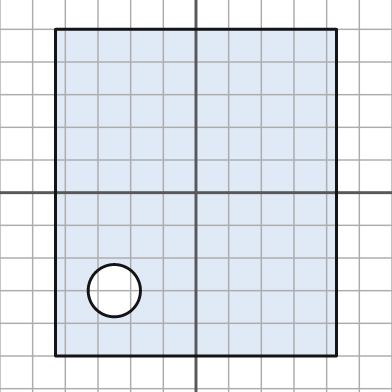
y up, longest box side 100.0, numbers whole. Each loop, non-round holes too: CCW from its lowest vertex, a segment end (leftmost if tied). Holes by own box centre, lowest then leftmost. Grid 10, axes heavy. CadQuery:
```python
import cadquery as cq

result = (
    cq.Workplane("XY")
    .moveTo(-43.0, -50.0)
    .lineTo(43.0, -50.0)
    .lineTo(43.0, 50.0)
    .lineTo(-43.0, 50.0)
    .close()
    .moveTo(-25.0, -30.0)
    .circle(8.0)
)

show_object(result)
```